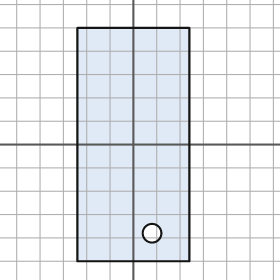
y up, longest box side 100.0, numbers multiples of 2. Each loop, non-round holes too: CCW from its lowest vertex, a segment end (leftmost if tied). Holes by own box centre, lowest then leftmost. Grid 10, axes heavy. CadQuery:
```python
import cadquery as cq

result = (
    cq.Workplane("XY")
    .moveTo(-24.0, -50.0)
    .lineTo(24.0, -50.0)
    .lineTo(24.0, 50.0)
    .lineTo(-24.0, 50.0)
    .close()
    .moveTo(8.0, -38.0)
    .circle(4.0)
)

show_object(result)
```